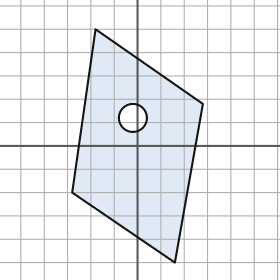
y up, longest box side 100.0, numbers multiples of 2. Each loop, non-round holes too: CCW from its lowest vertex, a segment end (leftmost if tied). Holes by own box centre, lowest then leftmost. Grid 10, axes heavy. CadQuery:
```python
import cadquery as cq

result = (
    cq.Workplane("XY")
    .moveTo(16.0, -50.0)
    .lineTo(28.0, 18.0)
    .lineTo(-18.0, 50.0)
    .lineTo(-28.0, -20.0)
    .close()
    .moveTo(-2.0, 12.0)
    .circle(6.0)
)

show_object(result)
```